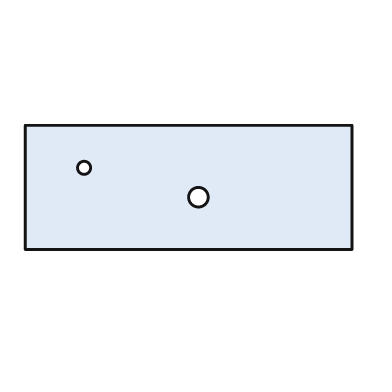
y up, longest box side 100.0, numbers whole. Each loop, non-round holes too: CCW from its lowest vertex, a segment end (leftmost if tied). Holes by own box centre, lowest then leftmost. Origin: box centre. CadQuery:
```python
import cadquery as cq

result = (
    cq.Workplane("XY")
    .moveTo(-50.0, -19.0)
    .lineTo(50.0, -19.0)
    .lineTo(50.0, 19.0)
    .lineTo(-50.0, 19.0)
    .close()
    .moveTo(3.0, -3.0)
    .circle(3.0)
    .moveTo(-32.0, 6.0)
    .circle(2.0)
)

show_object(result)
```